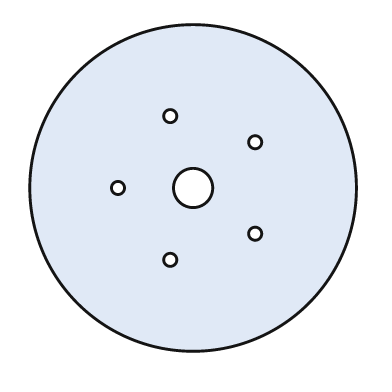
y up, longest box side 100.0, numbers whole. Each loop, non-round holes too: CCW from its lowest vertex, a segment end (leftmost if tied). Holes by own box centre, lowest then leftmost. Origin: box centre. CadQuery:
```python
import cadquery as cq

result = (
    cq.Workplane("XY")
    .moveTo(0.0, 0.0)
    .circle(50.0)
    .moveTo(-7.0, -22.0)
    .circle(2.0)
    .moveTo(19.0, -14.0)
    .circle(2.0)
    .moveTo(-23.0, 0.0)
    .circle(2.0)
    .moveTo(0.0, 0.0)
    .circle(6.0)
    .moveTo(19.0, 14.0)
    .circle(2.0)
    .moveTo(-7.0, 22.0)
    .circle(2.0)
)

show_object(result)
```